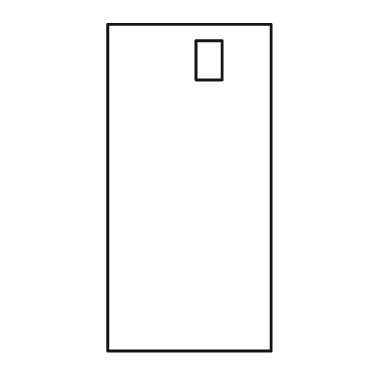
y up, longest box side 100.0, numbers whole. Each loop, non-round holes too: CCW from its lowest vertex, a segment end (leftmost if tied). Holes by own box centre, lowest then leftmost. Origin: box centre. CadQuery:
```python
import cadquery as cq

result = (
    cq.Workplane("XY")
    .moveTo(-25.0, -50.0)
    .lineTo(25.0, -50.0)
    .lineTo(25.0, 50.0)
    .lineTo(-25.0, 50.0)
    .close()
    .moveTo(2.0, 33.0)
    .lineTo(10.0, 33.0)
    .lineTo(10.0, 45.0)
    .lineTo(2.0, 45.0)
    .close()
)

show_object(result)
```